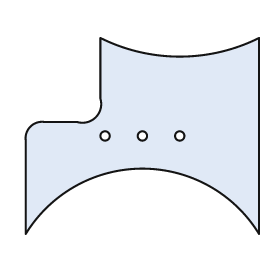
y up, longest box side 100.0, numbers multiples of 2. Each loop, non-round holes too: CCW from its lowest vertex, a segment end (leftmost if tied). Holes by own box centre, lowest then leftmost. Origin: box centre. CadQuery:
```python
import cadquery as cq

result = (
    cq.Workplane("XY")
    .moveTo(-50.0, -42.0)
    .threePointArc((0.0, -14.0), (50.0, -42.0))
    .lineTo(50.0, 42.0)
    .threePointArc((16.0, 34.0), (-18.0, 42.0))
    .lineTo(-18.0, 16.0)
    .threePointArc((-20.0, 8.0), (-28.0, 6.0))
    .lineTo(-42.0, 6.0)
    .threePointArc((-48.0, 4.0), (-50.0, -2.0))
    .close()
    .moveTo(-16.0, 0.0)
    .circle(2.0)
    .moveTo(0.0, 0.0)
    .circle(2.0)
    .moveTo(16.0, 0.0)
    .circle(2.0)
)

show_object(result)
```